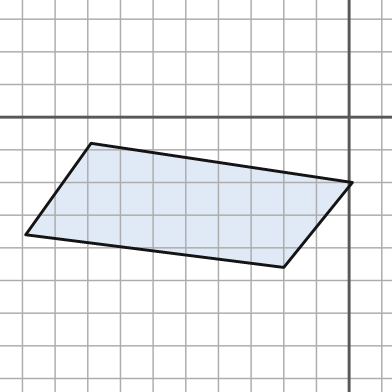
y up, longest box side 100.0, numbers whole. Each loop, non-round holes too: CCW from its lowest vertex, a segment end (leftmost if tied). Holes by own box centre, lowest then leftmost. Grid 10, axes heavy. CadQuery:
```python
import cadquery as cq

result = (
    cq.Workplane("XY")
    .moveTo(-20.0, -46.0)
    .lineTo(1.0, -20.0)
    .lineTo(-79.0, -8.0)
    .lineTo(-99.0, -36.0)
    .close()
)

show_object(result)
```